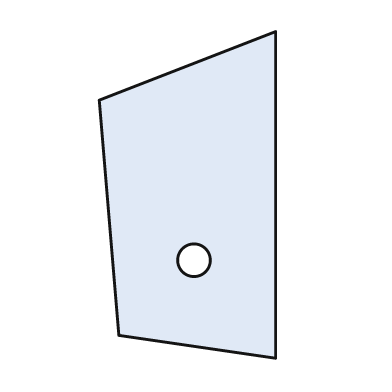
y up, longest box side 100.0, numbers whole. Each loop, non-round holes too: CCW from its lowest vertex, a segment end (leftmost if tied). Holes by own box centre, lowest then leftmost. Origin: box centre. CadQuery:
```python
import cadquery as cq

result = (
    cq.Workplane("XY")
    .moveTo(27.0, -50.0)
    .lineTo(27.0, 50.0)
    .lineTo(-27.0, 29.0)
    .lineTo(-21.0, -43.0)
    .close()
    .moveTo(2.0, -20.0)
    .circle(5.0)
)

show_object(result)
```